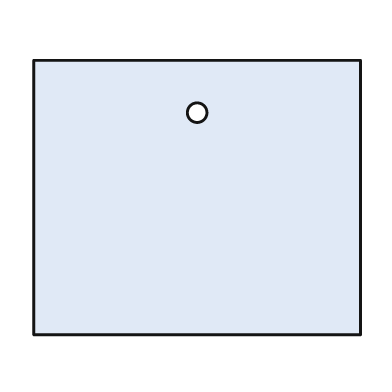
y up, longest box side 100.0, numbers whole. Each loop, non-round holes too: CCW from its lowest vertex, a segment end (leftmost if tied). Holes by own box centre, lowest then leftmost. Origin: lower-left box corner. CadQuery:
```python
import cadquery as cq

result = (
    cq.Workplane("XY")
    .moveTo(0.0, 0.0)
    .lineTo(100.0, 0.0)
    .lineTo(100.0, 84.0)
    .lineTo(0.0, 84.0)
    .close()
    .moveTo(50.0, 68.0)
    .circle(3.0)
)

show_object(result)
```